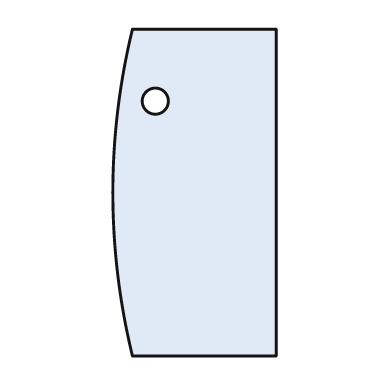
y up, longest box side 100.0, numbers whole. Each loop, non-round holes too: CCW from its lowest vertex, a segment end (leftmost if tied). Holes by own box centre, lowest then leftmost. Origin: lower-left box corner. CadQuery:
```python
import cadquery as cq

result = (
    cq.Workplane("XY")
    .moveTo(6.0, 0.0)
    .lineTo(50.0, 0.0)
    .lineTo(50.0, 100.0)
    .lineTo(6.0, 100.0)
    .threePointArc((0.0, 50.0), (6.0, 0.0))
    .close()
    .moveTo(13.0, 78.0)
    .circle(4.0)
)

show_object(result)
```